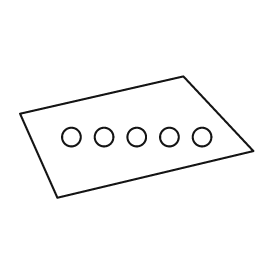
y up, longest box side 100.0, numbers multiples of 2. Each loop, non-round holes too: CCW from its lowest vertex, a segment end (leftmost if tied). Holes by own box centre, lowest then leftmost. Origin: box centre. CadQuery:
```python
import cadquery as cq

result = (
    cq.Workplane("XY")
    .moveTo(-34.0, -26.0)
    .lineTo(50.0, -6.0)
    .lineTo(20.0, 26.0)
    .lineTo(-50.0, 10.0)
    .close()
    .moveTo(-28.0, 0.0)
    .circle(4.0)
    .moveTo(-14.0, 0.0)
    .circle(4.0)
    .moveTo(0.0, 0.0)
    .circle(4.0)
    .moveTo(14.0, 0.0)
    .circle(4.0)
    .moveTo(28.0, 0.0)
    .circle(4.0)
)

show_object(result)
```